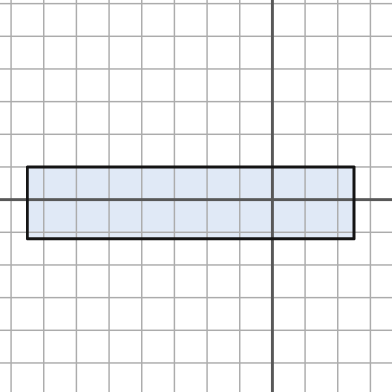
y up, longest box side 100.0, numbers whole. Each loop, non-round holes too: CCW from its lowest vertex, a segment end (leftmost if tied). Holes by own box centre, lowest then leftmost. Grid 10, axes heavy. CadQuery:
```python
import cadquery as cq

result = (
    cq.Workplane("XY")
    .moveTo(-75.0, -12.0)
    .lineTo(25.0, -12.0)
    .lineTo(25.0, 10.0)
    .lineTo(-75.0, 10.0)
    .close()
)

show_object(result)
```